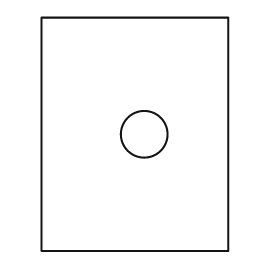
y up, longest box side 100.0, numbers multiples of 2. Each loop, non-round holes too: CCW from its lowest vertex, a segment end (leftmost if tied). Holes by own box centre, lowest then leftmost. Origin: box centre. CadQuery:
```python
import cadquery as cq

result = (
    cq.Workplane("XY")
    .moveTo(-40.0, -50.0)
    .lineTo(40.0, -50.0)
    .lineTo(40.0, 50.0)
    .lineTo(-40.0, 50.0)
    .close()
    .moveTo(4.0, 0.0)
    .circle(10.0)
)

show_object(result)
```